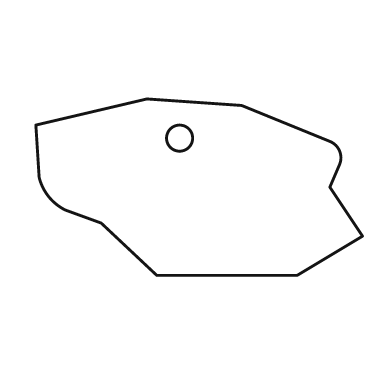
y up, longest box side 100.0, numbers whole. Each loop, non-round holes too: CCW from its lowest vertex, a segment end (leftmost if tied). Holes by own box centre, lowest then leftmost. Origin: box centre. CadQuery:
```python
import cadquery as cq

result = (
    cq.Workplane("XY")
    .moveTo(-13.0, -27.0)
    .lineTo(30.0, -27.0)
    .lineTo(50.0, -15.0)
    .lineTo(40.0, 0.0)
    .lineTo(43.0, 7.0)
    .threePointArc((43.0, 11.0), (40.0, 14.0))
    .lineTo(13.0, 25.0)
    .lineTo(-16.0, 27.0)
    .lineTo(-50.0, 19.0)
    .lineTo(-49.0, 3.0)
    .threePointArc((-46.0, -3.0), (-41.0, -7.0))
    .lineTo(-30.0, -11.0)
    .close()
    .moveTo(-6.0, 15.0)
    .circle(4.0)
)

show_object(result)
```